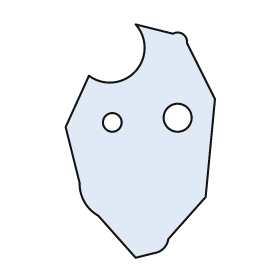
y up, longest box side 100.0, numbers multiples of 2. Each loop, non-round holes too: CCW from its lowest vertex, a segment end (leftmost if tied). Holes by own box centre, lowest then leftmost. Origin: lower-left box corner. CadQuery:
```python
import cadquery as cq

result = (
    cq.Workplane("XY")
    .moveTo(30.0, 0.0)
    .lineTo(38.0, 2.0)
    .threePointArc((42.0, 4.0), (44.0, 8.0))
    .lineTo(60.0, 26.0)
    .lineTo(64.0, 68.0)
    .lineTo(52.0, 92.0)
    .threePointArc((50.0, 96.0), (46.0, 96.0))
    .lineTo(30.0, 100.0)
    .threePointArc((30.0, 80.0), (10.0, 78.0))
    .lineTo(0.0, 56.0)
    .lineTo(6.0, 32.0)
    .threePointArc((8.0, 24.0), (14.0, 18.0))
    .close()
    .moveTo(20.0, 58.0)
    .circle(4.0)
    .moveTo(48.0, 60.0)
    .circle(6.0)
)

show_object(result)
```